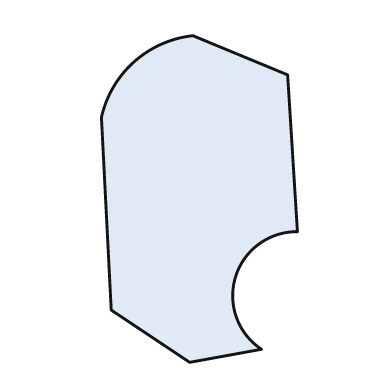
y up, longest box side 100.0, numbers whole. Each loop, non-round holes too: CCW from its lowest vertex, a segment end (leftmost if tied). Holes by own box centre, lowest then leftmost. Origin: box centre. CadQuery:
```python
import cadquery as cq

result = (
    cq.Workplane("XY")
    .moveTo(-3.0, -50.0)
    .lineTo(19.0, -46.0)
    .threePointArc((11.0, -24.0), (30.0, -10.0))
    .lineTo(27.0, 38.0)
    .lineTo(-2.0, 50.0)
    .threePointArc((-20.0, 42.0), (-30.0, 25.0))
    .lineTo(-27.0, -34.0)
    .close()
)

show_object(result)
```